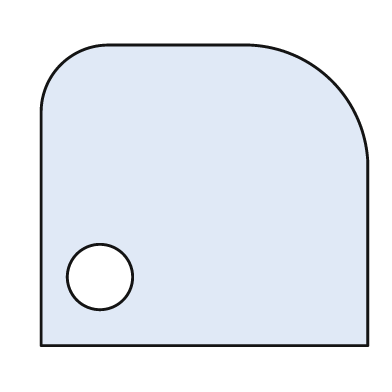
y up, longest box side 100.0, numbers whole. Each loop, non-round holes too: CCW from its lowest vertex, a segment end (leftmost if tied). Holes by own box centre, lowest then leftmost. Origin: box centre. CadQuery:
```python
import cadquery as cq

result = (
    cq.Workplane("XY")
    .moveTo(-50.0, -46.0)
    .lineTo(50.0, -46.0)
    .lineTo(50.0, 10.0)
    .threePointArc((39.0, 35.0), (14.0, 46.0))
    .lineTo(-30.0, 46.0)
    .threePointArc((-44.0, 40.0), (-50.0, 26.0))
    .close()
    .moveTo(-32.0, -25.0)
    .circle(10.0)
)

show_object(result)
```